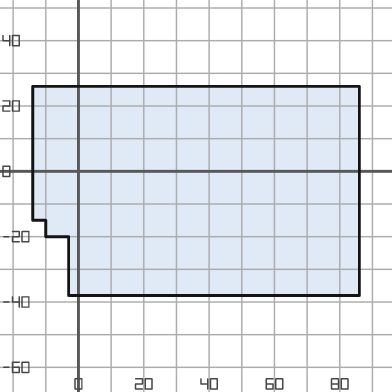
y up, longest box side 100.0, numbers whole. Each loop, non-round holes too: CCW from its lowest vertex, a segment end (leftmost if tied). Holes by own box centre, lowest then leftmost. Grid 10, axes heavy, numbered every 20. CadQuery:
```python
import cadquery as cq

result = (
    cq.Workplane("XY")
    .moveTo(-3.0, -38.0)
    .lineTo(86.0, -38.0)
    .lineTo(86.0, 26.0)
    .lineTo(-14.0, 26.0)
    .lineTo(-14.0, -15.0)
    .lineTo(-10.0, -15.0)
    .lineTo(-10.0, -20.0)
    .lineTo(-3.0, -20.0)
    .close()
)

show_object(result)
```